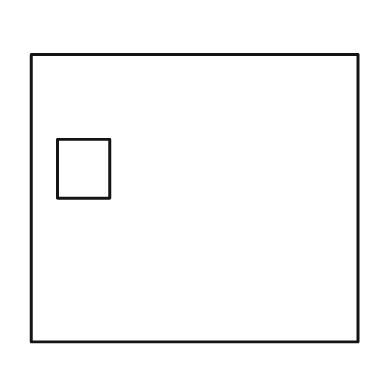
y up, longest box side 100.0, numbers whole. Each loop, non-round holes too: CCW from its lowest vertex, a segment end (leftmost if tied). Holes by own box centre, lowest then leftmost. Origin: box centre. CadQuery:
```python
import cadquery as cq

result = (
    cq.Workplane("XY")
    .moveTo(-50.0, -44.0)
    .lineTo(50.0, -44.0)
    .lineTo(50.0, 44.0)
    .lineTo(-50.0, 44.0)
    .close()
    .moveTo(-42.0, 0.0)
    .lineTo(-26.0, 0.0)
    .lineTo(-26.0, 18.0)
    .lineTo(-42.0, 18.0)
    .close()
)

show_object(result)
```